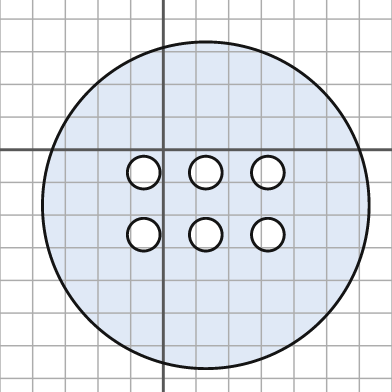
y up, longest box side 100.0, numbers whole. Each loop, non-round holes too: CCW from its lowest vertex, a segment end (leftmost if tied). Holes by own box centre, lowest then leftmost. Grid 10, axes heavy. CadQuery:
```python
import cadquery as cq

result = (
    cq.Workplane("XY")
    .moveTo(13.0, -17.0)
    .circle(50.0)
    .moveTo(-6.0, -26.0)
    .circle(5.0)
    .moveTo(13.0, -26.0)
    .circle(5.0)
    .moveTo(32.0, -26.0)
    .circle(5.0)
    .moveTo(-6.0, -7.0)
    .circle(5.0)
    .moveTo(13.0, -7.0)
    .circle(5.0)
    .moveTo(32.0, -7.0)
    .circle(5.0)
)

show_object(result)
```